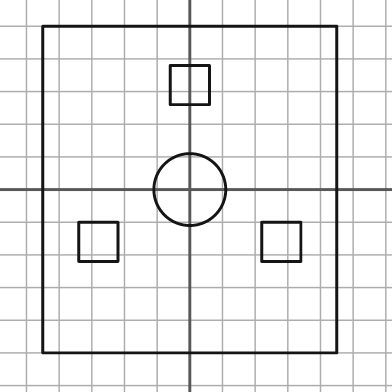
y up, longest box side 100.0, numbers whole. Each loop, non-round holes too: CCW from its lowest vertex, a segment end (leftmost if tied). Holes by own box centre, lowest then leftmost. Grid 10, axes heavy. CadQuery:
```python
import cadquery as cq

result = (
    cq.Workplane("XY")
    .moveTo(-45.0, -50.0)
    .lineTo(45.0, -50.0)
    .lineTo(45.0, 50.0)
    .lineTo(-45.0, 50.0)
    .close()
    .moveTo(-34.0, -22.0)
    .lineTo(-22.0, -22.0)
    .lineTo(-22.0, -10.0)
    .lineTo(-34.0, -10.0)
    .close()
    .moveTo(22.0, -22.0)
    .lineTo(34.0, -22.0)
    .lineTo(34.0, -10.0)
    .lineTo(22.0, -10.0)
    .close()
    .moveTo(0.0, 0.0)
    .circle(11.0)
    .moveTo(-6.0, 26.0)
    .lineTo(6.0, 26.0)
    .lineTo(6.0, 38.0)
    .lineTo(-6.0, 38.0)
    .close()
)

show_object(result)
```